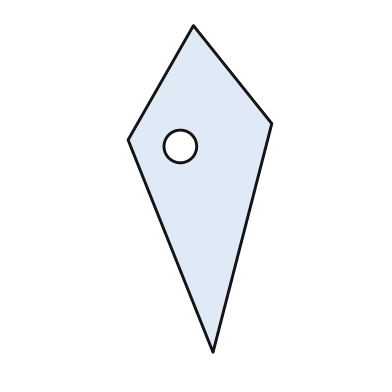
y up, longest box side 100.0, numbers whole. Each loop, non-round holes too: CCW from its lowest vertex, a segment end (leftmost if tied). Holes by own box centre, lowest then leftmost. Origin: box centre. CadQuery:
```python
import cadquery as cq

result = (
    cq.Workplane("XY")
    .moveTo(4.0, -50.0)
    .lineTo(22.0, 20.0)
    .lineTo(-2.0, 50.0)
    .lineTo(-22.0, 15.0)
    .close()
    .moveTo(-6.0, 13.0)
    .circle(5.0)
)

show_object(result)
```